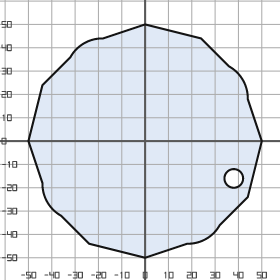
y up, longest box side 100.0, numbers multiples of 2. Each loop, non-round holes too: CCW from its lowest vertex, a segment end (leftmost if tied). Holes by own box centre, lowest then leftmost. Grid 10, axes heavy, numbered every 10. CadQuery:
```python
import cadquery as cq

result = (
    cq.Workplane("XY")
    .moveTo(0.0, -50.0)
    .lineTo(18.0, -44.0)
    .threePointArc((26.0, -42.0), (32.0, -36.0))
    .lineTo(44.0, -24.0)
    .lineTo(50.0, 0.0)
    .lineTo(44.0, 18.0)
    .threePointArc((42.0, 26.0), (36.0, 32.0))
    .lineTo(24.0, 44.0)
    .lineTo(0.0, 50.0)
    .lineTo(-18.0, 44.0)
    .threePointArc((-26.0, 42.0), (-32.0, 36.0))
    .lineTo(-44.0, 24.0)
    .lineTo(-50.0, 0.0)
    .lineTo(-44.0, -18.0)
    .threePointArc((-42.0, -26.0), (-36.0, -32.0))
    .lineTo(-24.0, -44.0)
    .close()
    .moveTo(38.0, -16.0)
    .circle(4.0)
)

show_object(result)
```